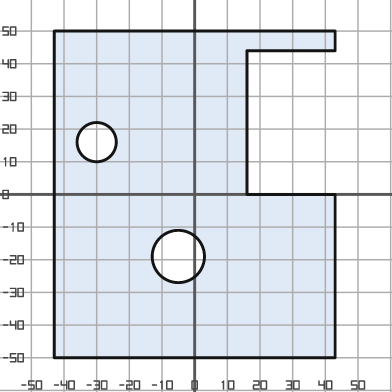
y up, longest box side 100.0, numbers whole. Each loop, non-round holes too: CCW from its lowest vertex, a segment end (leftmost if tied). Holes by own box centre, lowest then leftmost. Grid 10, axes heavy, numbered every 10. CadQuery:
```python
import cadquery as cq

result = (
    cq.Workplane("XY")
    .moveTo(-43.0, -50.0)
    .lineTo(43.0, -50.0)
    .lineTo(43.0, 0.0)
    .lineTo(16.0, 0.0)
    .lineTo(16.0, 44.0)
    .lineTo(43.0, 44.0)
    .lineTo(43.0, 50.0)
    .lineTo(-43.0, 50.0)
    .close()
    .moveTo(-5.0, -19.0)
    .circle(8.0)
    .moveTo(-30.0, 16.0)
    .circle(6.0)
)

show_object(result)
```